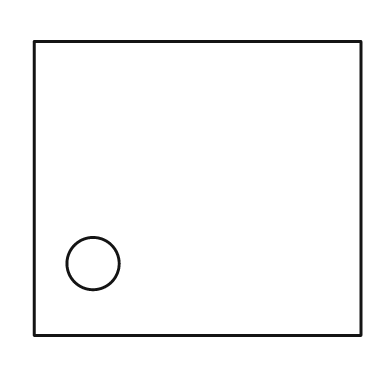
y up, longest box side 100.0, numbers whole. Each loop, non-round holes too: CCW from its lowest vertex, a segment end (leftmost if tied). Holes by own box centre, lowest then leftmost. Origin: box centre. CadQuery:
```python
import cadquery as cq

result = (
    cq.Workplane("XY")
    .moveTo(-50.0, -45.0)
    .lineTo(50.0, -45.0)
    .lineTo(50.0, 45.0)
    .lineTo(-50.0, 45.0)
    .close()
    .moveTo(-32.0, -23.0)
    .circle(8.0)
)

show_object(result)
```